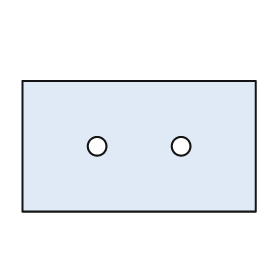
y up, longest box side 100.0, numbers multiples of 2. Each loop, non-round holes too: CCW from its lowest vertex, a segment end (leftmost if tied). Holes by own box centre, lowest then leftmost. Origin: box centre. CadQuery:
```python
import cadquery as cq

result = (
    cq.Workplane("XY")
    .moveTo(-50.0, -28.0)
    .lineTo(50.0, -28.0)
    .lineTo(50.0, 28.0)
    .lineTo(-50.0, 28.0)
    .close()
    .moveTo(-18.0, 0.0)
    .circle(4.0)
    .moveTo(18.0, 0.0)
    .circle(4.0)
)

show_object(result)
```